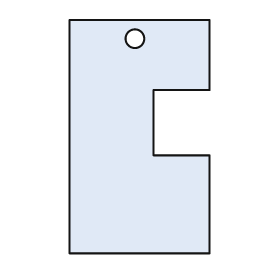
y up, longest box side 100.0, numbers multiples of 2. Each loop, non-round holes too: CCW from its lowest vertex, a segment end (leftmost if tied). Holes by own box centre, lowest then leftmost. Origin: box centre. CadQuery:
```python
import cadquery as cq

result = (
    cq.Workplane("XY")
    .moveTo(-30.0, -50.0)
    .lineTo(30.0, -50.0)
    .lineTo(30.0, -8.0)
    .lineTo(6.0, -8.0)
    .lineTo(6.0, 20.0)
    .lineTo(30.0, 20.0)
    .lineTo(30.0, 50.0)
    .lineTo(-30.0, 50.0)
    .close()
    .moveTo(-2.0, 42.0)
    .circle(4.0)
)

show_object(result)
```